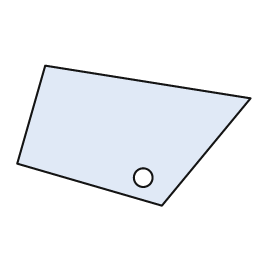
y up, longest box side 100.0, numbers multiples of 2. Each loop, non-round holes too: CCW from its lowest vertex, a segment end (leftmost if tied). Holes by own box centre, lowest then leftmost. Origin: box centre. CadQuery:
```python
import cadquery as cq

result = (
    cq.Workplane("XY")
    .moveTo(12.0, -30.0)
    .lineTo(50.0, 16.0)
    .lineTo(-38.0, 30.0)
    .lineTo(-50.0, -12.0)
    .close()
    .moveTo(4.0, -18.0)
    .circle(4.0)
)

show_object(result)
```